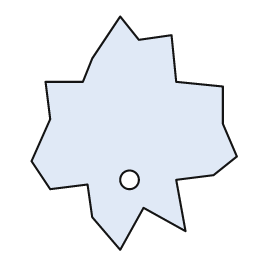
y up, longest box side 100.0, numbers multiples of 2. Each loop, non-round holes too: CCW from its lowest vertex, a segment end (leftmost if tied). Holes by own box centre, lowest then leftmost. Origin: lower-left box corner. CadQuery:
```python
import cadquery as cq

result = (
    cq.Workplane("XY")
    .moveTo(38.0, 0.0)
    .lineTo(48.0, 18.0)
    .lineTo(66.0, 8.0)
    .lineTo(62.0, 30.0)
    .lineTo(78.0, 32.0)
    .lineTo(88.0, 40.0)
    .lineTo(82.0, 54.0)
    .lineTo(82.0, 70.0)
    .lineTo(62.0, 72.0)
    .lineTo(60.0, 92.0)
    .lineTo(46.0, 90.0)
    .lineTo(38.0, 100.0)
    .lineTo(26.0, 82.0)
    .lineTo(22.0, 72.0)
    .lineTo(6.0, 72.0)
    .lineTo(8.0, 56.0)
    .lineTo(0.0, 38.0)
    .lineTo(8.0, 26.0)
    .lineTo(24.0, 28.0)
    .lineTo(26.0, 14.0)
    .close()
    .moveTo(42.0, 30.0)
    .circle(4.0)
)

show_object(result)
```